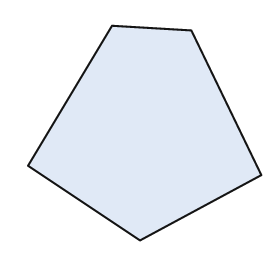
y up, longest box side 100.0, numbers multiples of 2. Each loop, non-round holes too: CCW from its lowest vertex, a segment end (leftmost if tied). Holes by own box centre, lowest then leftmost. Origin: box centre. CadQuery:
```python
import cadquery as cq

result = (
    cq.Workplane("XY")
    .moveTo(-2.0, -46.0)
    .lineTo(50.0, -18.0)
    .lineTo(20.0, 44.0)
    .lineTo(-14.0, 46.0)
    .lineTo(-50.0, -14.0)
    .close()
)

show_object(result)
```